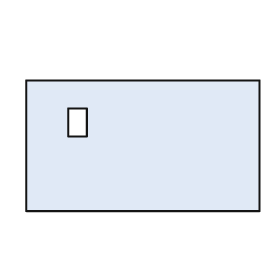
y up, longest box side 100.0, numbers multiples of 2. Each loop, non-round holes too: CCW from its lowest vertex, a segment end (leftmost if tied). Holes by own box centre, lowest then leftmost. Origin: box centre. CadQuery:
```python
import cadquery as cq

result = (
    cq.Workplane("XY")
    .moveTo(-50.0, -28.0)
    .lineTo(50.0, -28.0)
    .lineTo(50.0, 28.0)
    .lineTo(-50.0, 28.0)
    .close()
    .moveTo(-32.0, 4.0)
    .lineTo(-24.0, 4.0)
    .lineTo(-24.0, 16.0)
    .lineTo(-32.0, 16.0)
    .close()
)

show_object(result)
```